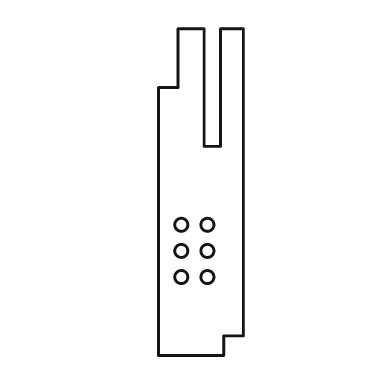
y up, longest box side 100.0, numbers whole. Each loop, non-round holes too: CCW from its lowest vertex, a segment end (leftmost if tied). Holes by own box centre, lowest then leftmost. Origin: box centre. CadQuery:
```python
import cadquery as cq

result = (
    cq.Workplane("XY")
    .moveTo(-13.0, -50.0)
    .lineTo(7.0, -50.0)
    .lineTo(7.0, -44.0)
    .lineTo(13.0, -44.0)
    .lineTo(13.0, 50.0)
    .lineTo(6.0, 50.0)
    .lineTo(6.0, 14.0)
    .lineTo(1.0, 14.0)
    .lineTo(1.0, 50.0)
    .lineTo(-7.0, 50.0)
    .lineTo(-7.0, 32.0)
    .lineTo(-13.0, 32.0)
    .close()
    .moveTo(-6.0, -26.0)
    .circle(2.0)
    .moveTo(2.0, -26.0)
    .circle(2.0)
    .moveTo(-6.0, -18.0)
    .circle(2.0)
    .moveTo(2.0, -18.0)
    .circle(2.0)
    .moveTo(-6.0, -10.0)
    .circle(2.0)
    .moveTo(2.0, -10.0)
    .circle(2.0)
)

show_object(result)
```